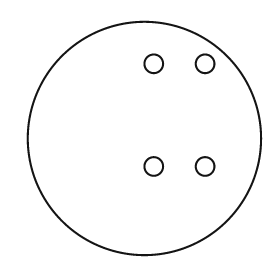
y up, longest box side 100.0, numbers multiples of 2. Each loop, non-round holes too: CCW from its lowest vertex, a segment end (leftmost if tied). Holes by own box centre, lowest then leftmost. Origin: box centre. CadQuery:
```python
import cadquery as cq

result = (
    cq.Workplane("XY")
    .moveTo(0.0, 0.0)
    .circle(50.0)
    .moveTo(4.0, -12.0)
    .circle(4.0)
    .moveTo(26.0, -12.0)
    .circle(4.0)
    .moveTo(4.0, 32.0)
    .circle(4.0)
    .moveTo(26.0, 32.0)
    .circle(4.0)
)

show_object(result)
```